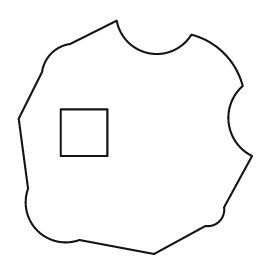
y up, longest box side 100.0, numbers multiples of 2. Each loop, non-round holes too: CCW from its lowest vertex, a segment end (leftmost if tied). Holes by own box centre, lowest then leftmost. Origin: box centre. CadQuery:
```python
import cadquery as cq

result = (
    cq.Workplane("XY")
    .moveTo(8.0, -50.0)
    .lineTo(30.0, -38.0)
    .threePointArc((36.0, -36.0), (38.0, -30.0))
    .lineTo(50.0, -8.0)
    .threePointArc((40.0, 6.0), (46.0, 22.0))
    .threePointArc((38.0, 36.0), (24.0, 44.0))
    .threePointArc((6.0, 36.0), (-8.0, 50.0))
    .lineTo(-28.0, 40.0)
    .threePointArc((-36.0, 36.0), (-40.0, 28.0))
    .lineTo(-50.0, 8.0)
    .lineTo(-46.0, -22.0)
    .threePointArc((-42.0, -40.0), (-24.0, -44.0))
    .close()
    .moveTo(-32.0, -8.0)
    .lineTo(-12.0, -8.0)
    .lineTo(-12.0, 12.0)
    .lineTo(-32.0, 12.0)
    .close()
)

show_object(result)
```